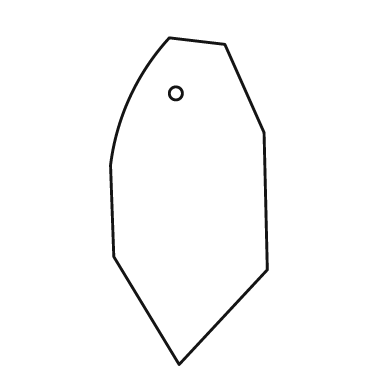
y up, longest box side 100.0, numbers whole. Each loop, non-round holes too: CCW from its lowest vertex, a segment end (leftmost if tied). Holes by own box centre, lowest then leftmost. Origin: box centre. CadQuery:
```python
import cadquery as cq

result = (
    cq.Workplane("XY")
    .moveTo(-3.0, -50.0)
    .lineTo(24.0, -21.0)
    .lineTo(23.0, 21.0)
    .lineTo(11.0, 48.0)
    .lineTo(-6.0, 50.0)
    .threePointArc((-18.0, 32.0), (-24.0, 11.0))
    .lineTo(-23.0, -17.0)
    .close()
    .moveTo(-4.0, 33.0)
    .circle(2.0)
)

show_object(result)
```